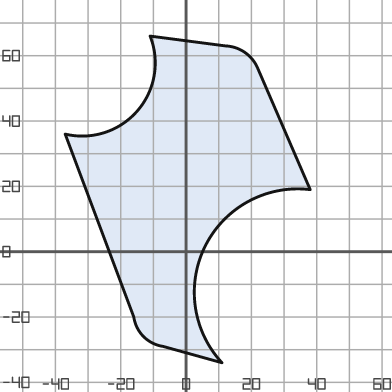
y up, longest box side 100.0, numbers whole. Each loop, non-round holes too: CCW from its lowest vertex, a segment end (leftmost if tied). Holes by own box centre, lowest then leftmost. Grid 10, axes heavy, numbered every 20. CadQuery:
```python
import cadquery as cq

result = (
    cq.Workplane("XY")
    .moveTo(11.0, -34.0)
    .threePointArc((6.0, 2.0), (38.0, 19.0))
    .lineTo(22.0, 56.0)
    .threePointArc((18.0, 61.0), (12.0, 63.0))
    .lineTo(-11.0, 66.0)
    .threePointArc((-15.0, 43.0), (-37.0, 36.0))
    .lineTo(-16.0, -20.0)
    .threePointArc((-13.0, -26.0), (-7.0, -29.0))
    .close()
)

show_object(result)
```